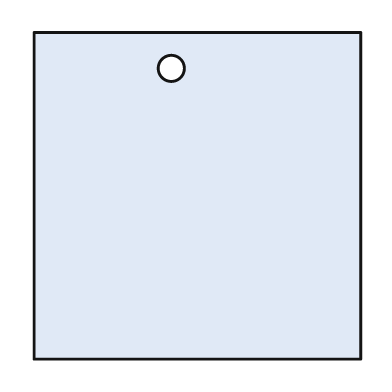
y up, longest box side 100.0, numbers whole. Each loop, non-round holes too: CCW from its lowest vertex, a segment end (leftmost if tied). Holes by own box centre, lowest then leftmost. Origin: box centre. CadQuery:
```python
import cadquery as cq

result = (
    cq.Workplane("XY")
    .moveTo(-50.0, -50.0)
    .lineTo(50.0, -50.0)
    .lineTo(50.0, 50.0)
    .lineTo(-50.0, 50.0)
    .close()
    .moveTo(-8.0, 39.0)
    .circle(4.0)
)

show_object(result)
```